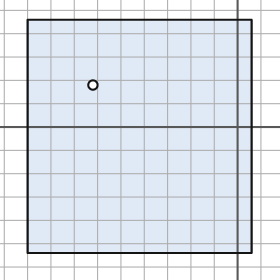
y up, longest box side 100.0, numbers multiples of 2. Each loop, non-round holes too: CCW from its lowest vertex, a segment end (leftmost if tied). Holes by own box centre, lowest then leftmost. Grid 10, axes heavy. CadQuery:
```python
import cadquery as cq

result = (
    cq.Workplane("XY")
    .moveTo(-90.0, -54.0)
    .lineTo(6.0, -54.0)
    .lineTo(6.0, 46.0)
    .lineTo(-90.0, 46.0)
    .close()
    .moveTo(-62.0, 18.0)
    .circle(2.0)
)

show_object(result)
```